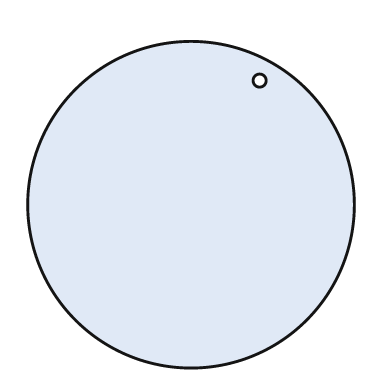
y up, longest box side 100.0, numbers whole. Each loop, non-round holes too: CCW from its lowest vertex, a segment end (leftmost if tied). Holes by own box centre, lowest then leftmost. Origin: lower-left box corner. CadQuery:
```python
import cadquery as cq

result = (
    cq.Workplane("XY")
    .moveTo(50.0, 50.0)
    .circle(50.0)
    .moveTo(71.0, 88.0)
    .circle(2.0)
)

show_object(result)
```